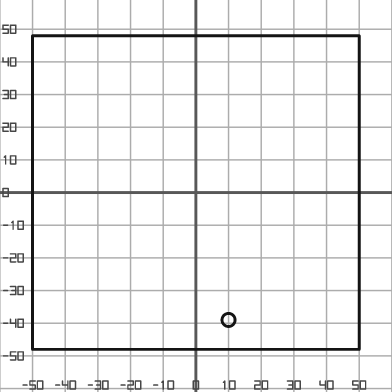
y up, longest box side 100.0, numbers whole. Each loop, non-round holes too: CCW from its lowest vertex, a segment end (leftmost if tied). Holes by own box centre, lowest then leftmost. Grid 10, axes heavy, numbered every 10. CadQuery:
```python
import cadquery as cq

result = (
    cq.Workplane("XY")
    .moveTo(-50.0, -48.0)
    .lineTo(50.0, -48.0)
    .lineTo(50.0, 48.0)
    .lineTo(-50.0, 48.0)
    .close()
    .moveTo(10.0, -39.0)
    .circle(2.0)
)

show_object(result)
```